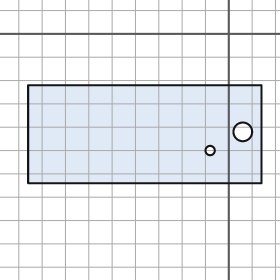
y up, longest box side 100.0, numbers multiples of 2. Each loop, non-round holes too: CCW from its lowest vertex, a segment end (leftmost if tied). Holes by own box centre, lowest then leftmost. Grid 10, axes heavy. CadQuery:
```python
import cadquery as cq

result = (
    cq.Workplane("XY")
    .moveTo(-86.0, -64.0)
    .lineTo(14.0, -64.0)
    .lineTo(14.0, -22.0)
    .lineTo(-86.0, -22.0)
    .close()
    .moveTo(-8.0, -50.0)
    .circle(2.0)
    .moveTo(6.0, -42.0)
    .circle(4.0)
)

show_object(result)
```